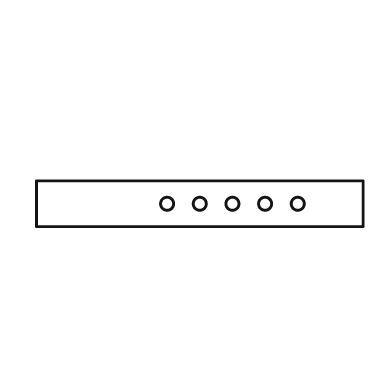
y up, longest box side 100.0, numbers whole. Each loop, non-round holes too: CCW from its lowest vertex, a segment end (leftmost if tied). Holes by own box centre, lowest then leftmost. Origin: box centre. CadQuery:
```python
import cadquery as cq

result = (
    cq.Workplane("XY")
    .moveTo(-50.0, -7.0)
    .lineTo(50.0, -7.0)
    .lineTo(50.0, 7.0)
    .lineTo(-50.0, 7.0)
    .close()
    .moveTo(-10.0, 0.0)
    .circle(2.0)
    .moveTo(0.0, 0.0)
    .circle(2.0)
    .moveTo(10.0, 0.0)
    .circle(2.0)
    .moveTo(20.0, 0.0)
    .circle(2.0)
    .moveTo(30.0, 0.0)
    .circle(2.0)
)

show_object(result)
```